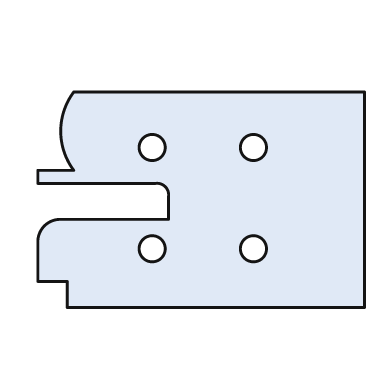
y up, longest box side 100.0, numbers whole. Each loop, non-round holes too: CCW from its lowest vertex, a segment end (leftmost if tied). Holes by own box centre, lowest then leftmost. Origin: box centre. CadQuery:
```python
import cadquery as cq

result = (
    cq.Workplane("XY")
    .moveTo(-41.0, -33.0)
    .lineTo(50.0, -33.0)
    .lineTo(50.0, 33.0)
    .lineTo(-39.0, 33.0)
    .threePointArc((-43.0, 21.0), (-39.0, 9.0))
    .lineTo(-50.0, 9.0)
    .lineTo(-50.0, 5.0)
    .lineTo(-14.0, 5.0)
    .threePointArc((-11.0, 4.0), (-10.0, 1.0))
    .lineTo(-10.0, -6.0)
    .lineTo(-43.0, -6.0)
    .threePointArc((-48.0, -8.0), (-50.0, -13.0))
    .lineTo(-50.0, -25.0)
    .lineTo(-41.0, -25.0)
    .close()
    .moveTo(-15.0, -15.0)
    .circle(4.0)
    .moveTo(16.0, -15.0)
    .circle(4.0)
    .moveTo(-15.0, 16.0)
    .circle(4.0)
    .moveTo(16.0, 16.0)
    .circle(4.0)
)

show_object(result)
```